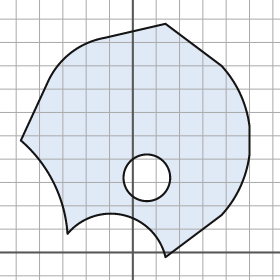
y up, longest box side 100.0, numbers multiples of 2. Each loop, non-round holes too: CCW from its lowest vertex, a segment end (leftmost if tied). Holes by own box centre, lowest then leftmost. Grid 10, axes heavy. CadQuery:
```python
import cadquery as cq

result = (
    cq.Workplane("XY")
    .moveTo(14.0, -2.0)
    .lineTo(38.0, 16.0)
    .threePointArc((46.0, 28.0), (50.0, 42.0))
    .lineTo(50.0, 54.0)
    .threePointArc((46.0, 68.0), (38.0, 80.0))
    .lineTo(14.0, 98.0)
    .lineTo(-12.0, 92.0)
    .threePointArc((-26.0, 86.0), (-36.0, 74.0))
    .lineTo(-48.0, 48.0)
    .threePointArc((-34.0, 30.0), (-28.0, 8.0))
    .threePointArc((-4.0, 16.0), (14.0, -2.0))
    .close()
    .moveTo(6.0, 32.0)
    .circle(10.0)
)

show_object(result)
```